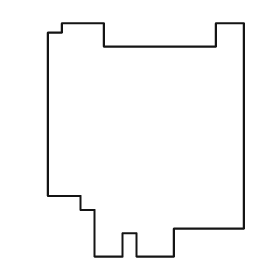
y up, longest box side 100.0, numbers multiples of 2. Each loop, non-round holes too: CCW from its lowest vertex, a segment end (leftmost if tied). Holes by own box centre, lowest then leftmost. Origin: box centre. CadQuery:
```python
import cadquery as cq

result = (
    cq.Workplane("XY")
    .moveTo(-22.0, -50.0)
    .lineTo(-10.0, -50.0)
    .lineTo(-10.0, -40.0)
    .lineTo(-4.0, -40.0)
    .lineTo(-4.0, -50.0)
    .lineTo(12.0, -50.0)
    .lineTo(12.0, -38.0)
    .lineTo(42.0, -38.0)
    .lineTo(42.0, 50.0)
    .lineTo(30.0, 50.0)
    .lineTo(30.0, 40.0)
    .lineTo(-18.0, 40.0)
    .lineTo(-18.0, 50.0)
    .lineTo(-36.0, 50.0)
    .lineTo(-36.0, 46.0)
    .lineTo(-42.0, 46.0)
    .lineTo(-42.0, -24.0)
    .lineTo(-28.0, -24.0)
    .lineTo(-28.0, -30.0)
    .lineTo(-22.0, -30.0)
    .close()
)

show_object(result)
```